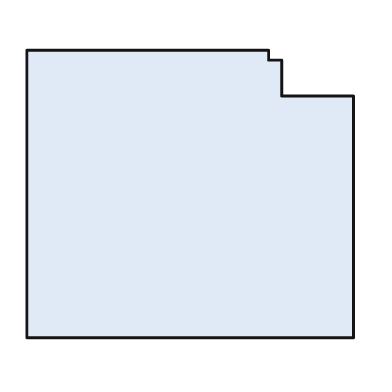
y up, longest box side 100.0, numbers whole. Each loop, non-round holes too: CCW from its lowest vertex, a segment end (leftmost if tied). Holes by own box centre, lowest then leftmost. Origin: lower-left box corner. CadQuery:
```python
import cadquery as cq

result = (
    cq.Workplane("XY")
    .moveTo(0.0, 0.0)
    .lineTo(100.0, 0.0)
    .lineTo(100.0, 74.0)
    .lineTo(78.0, 74.0)
    .lineTo(78.0, 85.0)
    .lineTo(74.0, 85.0)
    .lineTo(74.0, 88.0)
    .lineTo(0.0, 88.0)
    .close()
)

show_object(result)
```